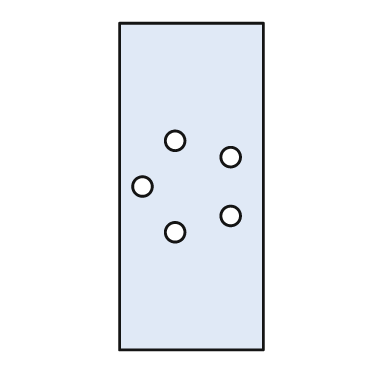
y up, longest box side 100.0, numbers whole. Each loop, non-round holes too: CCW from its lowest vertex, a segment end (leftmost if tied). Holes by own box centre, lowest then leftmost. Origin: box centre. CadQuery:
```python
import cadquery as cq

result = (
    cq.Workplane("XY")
    .moveTo(-22.0, -50.0)
    .lineTo(22.0, -50.0)
    .lineTo(22.0, 50.0)
    .lineTo(-22.0, 50.0)
    .close()
    .moveTo(-5.0, -14.0)
    .circle(3.0)
    .moveTo(12.0, -9.0)
    .circle(3.0)
    .moveTo(-15.0, 0.0)
    .circle(3.0)
    .moveTo(12.0, 9.0)
    .circle(3.0)
    .moveTo(-5.0, 14.0)
    .circle(3.0)
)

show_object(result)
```